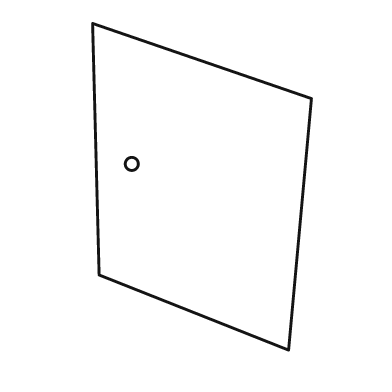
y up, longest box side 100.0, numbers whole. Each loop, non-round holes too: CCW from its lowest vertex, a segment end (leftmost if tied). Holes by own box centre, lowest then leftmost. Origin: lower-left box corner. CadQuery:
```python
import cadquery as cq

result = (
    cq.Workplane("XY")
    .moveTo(60.0, 0.0)
    .lineTo(67.0, 77.0)
    .lineTo(0.0, 100.0)
    .lineTo(2.0, 23.0)
    .close()
    .moveTo(12.0, 57.0)
    .circle(2.0)
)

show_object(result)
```